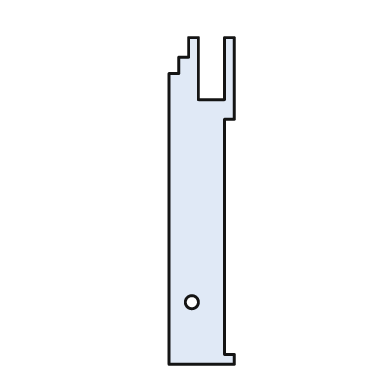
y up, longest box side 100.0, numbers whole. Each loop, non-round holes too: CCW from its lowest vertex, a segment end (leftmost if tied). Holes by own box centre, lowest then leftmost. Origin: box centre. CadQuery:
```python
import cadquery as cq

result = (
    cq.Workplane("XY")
    .moveTo(-10.0, -50.0)
    .lineTo(10.0, -50.0)
    .lineTo(10.0, -47.0)
    .lineTo(7.0, -47.0)
    .lineTo(7.0, 25.0)
    .lineTo(10.0, 25.0)
    .lineTo(10.0, 50.0)
    .lineTo(7.0, 50.0)
    .lineTo(7.0, 31.0)
    .lineTo(-1.0, 31.0)
    .lineTo(-1.0, 50.0)
    .lineTo(-4.0, 50.0)
    .lineTo(-4.0, 44.0)
    .lineTo(-7.0, 44.0)
    .lineTo(-7.0, 39.0)
    .lineTo(-10.0, 39.0)
    .close()
    .moveTo(-3.0, -31.0)
    .circle(2.0)
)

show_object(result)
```